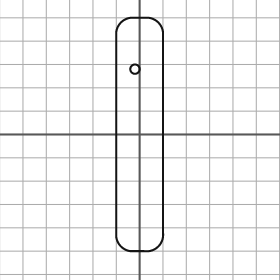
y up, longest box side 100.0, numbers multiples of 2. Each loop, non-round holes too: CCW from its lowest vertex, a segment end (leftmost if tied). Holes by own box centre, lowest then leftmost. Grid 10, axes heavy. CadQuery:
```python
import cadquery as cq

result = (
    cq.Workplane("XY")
    .moveTo(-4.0, -50.0)
    .lineTo(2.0, -50.0)
    .threePointArc((8.0, -48.0), (10.0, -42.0))
    .lineTo(10.0, 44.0)
    .threePointArc((8.0, 48.0), (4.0, 50.0))
    .lineTo(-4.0, 50.0)
    .threePointArc((-8.0, 48.0), (-10.0, 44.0))
    .lineTo(-10.0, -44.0)
    .threePointArc((-8.0, -48.0), (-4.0, -50.0))
    .close()
    .moveTo(-2.0, 28.0)
    .circle(2.0)
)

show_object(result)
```